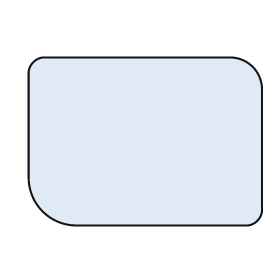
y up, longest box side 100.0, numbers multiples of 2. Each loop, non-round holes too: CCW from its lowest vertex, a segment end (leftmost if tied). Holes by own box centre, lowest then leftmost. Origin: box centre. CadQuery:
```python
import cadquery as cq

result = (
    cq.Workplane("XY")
    .moveTo(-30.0, -36.0)
    .lineTo(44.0, -36.0)
    .threePointArc((48.0, -34.0), (50.0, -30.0))
    .lineTo(50.0, 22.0)
    .threePointArc((46.0, 32.0), (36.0, 36.0))
    .lineTo(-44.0, 36.0)
    .threePointArc((-48.0, 34.0), (-50.0, 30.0))
    .lineTo(-50.0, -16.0)
    .threePointArc((-44.0, -30.0), (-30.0, -36.0))
    .close()
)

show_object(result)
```